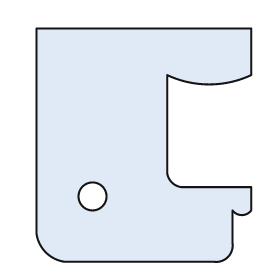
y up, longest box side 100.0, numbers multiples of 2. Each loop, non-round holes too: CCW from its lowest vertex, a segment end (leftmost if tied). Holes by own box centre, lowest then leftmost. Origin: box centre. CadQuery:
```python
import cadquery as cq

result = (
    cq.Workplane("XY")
    .moveTo(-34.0, -50.0)
    .lineTo(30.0, -50.0)
    .threePointArc((36.0, -48.0), (38.0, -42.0))
    .lineTo(38.0, -28.0)
    .threePointArc((42.0, -30.0), (46.0, -28.0))
    .lineTo(46.0, -18.0)
    .lineTo(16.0, -18.0)
    .threePointArc((12.0, -16.0), (10.0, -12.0))
    .lineTo(10.0, 30.0)
    .threePointArc((28.0, 26.0), (46.0, 30.0))
    .lineTo(46.0, 50.0)
    .lineTo(-46.0, 50.0)
    .lineTo(-46.0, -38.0)
    .threePointArc((-42.0, -46.0), (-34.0, -50.0))
    .close()
    .moveTo(-22.0, -22.0)
    .circle(6.0)
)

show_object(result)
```